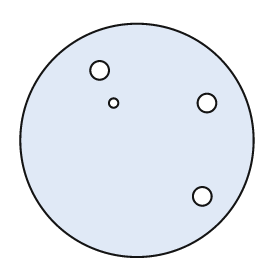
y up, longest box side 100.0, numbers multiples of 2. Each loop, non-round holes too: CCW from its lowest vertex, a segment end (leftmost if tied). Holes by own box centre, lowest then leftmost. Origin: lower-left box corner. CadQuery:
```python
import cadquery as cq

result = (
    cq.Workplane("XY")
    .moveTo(50.0, 50.0)
    .circle(50.0)
    .moveTo(78.0, 26.0)
    .circle(4.0)
    .moveTo(40.0, 66.0)
    .circle(2.0)
    .moveTo(80.0, 66.0)
    .circle(4.0)
    .moveTo(34.0, 80.0)
    .circle(4.0)
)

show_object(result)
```